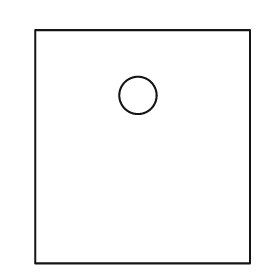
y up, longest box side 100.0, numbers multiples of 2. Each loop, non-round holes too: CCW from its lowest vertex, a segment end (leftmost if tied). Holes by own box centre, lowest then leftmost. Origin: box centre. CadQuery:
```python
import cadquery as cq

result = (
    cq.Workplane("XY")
    .moveTo(-46.0, -50.0)
    .lineTo(46.0, -50.0)
    .lineTo(46.0, 50.0)
    .lineTo(-46.0, 50.0)
    .close()
    .moveTo(-2.0, 22.0)
    .circle(8.0)
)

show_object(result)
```